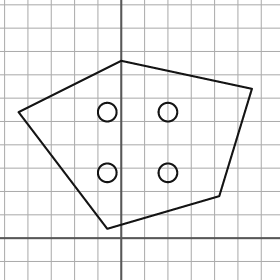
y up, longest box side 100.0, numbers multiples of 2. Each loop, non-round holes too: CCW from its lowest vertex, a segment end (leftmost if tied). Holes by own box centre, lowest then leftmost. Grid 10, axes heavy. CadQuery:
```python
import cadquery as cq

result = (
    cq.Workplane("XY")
    .moveTo(-6.0, 4.0)
    .lineTo(42.0, 18.0)
    .lineTo(56.0, 64.0)
    .lineTo(0.0, 76.0)
    .lineTo(-44.0, 54.0)
    .close()
    .moveTo(-6.0, 28.0)
    .circle(4.0)
    .moveTo(20.0, 28.0)
    .circle(4.0)
    .moveTo(-6.0, 54.0)
    .circle(4.0)
    .moveTo(20.0, 54.0)
    .circle(4.0)
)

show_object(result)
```